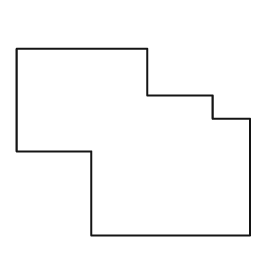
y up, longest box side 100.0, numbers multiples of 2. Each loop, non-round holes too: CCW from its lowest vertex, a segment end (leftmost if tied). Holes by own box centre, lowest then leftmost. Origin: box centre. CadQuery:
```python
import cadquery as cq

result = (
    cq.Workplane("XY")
    .moveTo(-18.0, -40.0)
    .lineTo(50.0, -40.0)
    .lineTo(50.0, 10.0)
    .lineTo(34.0, 10.0)
    .lineTo(34.0, 20.0)
    .lineTo(6.0, 20.0)
    .lineTo(6.0, 40.0)
    .lineTo(-50.0, 40.0)
    .lineTo(-50.0, -4.0)
    .lineTo(-18.0, -4.0)
    .close()
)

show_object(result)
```